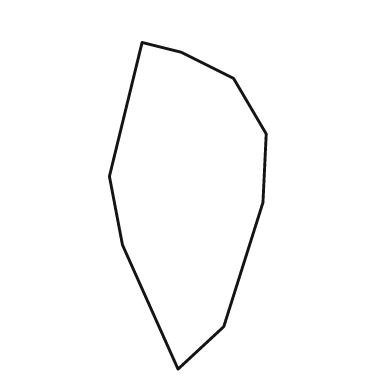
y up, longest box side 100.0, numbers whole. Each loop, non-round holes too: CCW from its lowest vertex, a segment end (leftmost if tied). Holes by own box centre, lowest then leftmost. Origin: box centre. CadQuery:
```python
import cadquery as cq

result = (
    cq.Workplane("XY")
    .moveTo(-3.0, -50.0)
    .lineTo(11.0, -37.0)
    .lineTo(23.0, 1.0)
    .lineTo(24.0, 22.0)
    .lineTo(14.0, 39.0)
    .lineTo(-2.0, 47.0)
    .lineTo(-14.0, 50.0)
    .lineTo(-24.0, 9.0)
    .lineTo(-20.0, -12.0)
    .close()
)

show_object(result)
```